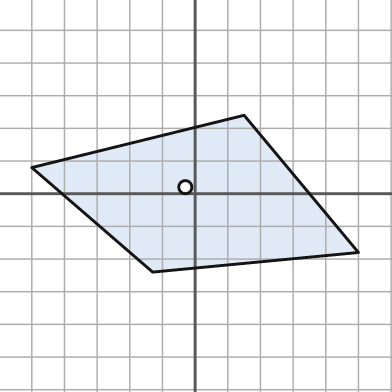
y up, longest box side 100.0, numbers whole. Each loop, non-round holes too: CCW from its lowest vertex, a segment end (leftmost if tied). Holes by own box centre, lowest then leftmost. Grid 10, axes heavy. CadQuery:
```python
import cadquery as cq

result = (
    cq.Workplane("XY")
    .moveTo(-13.0, -24.0)
    .lineTo(50.0, -18.0)
    .lineTo(15.0, 24.0)
    .lineTo(-50.0, 8.0)
    .close()
    .moveTo(-3.0, 2.0)
    .circle(2.0)
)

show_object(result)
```